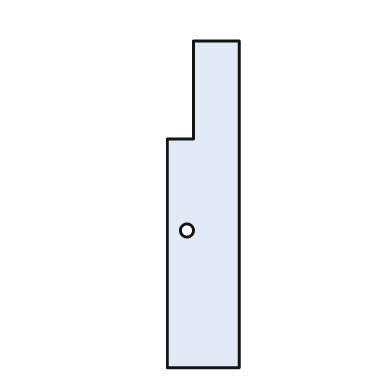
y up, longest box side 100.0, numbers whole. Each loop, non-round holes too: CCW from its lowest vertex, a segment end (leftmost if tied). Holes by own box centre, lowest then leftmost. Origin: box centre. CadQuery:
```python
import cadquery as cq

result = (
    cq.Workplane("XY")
    .moveTo(-11.0, -50.0)
    .lineTo(11.0, -50.0)
    .lineTo(11.0, 50.0)
    .lineTo(-3.0, 50.0)
    .lineTo(-3.0, 20.0)
    .lineTo(-11.0, 20.0)
    .close()
    .moveTo(-5.0, -8.0)
    .circle(2.0)
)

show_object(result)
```